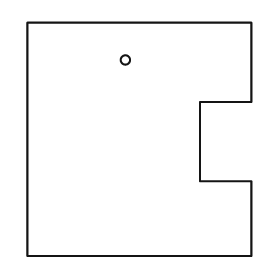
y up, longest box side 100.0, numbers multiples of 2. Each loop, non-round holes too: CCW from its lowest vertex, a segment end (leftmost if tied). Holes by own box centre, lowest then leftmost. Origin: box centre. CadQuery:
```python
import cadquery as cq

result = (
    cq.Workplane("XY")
    .moveTo(-48.0, -50.0)
    .lineTo(48.0, -50.0)
    .lineTo(48.0, -18.0)
    .lineTo(26.0, -18.0)
    .lineTo(26.0, 16.0)
    .lineTo(48.0, 16.0)
    .lineTo(48.0, 50.0)
    .lineTo(-48.0, 50.0)
    .close()
    .moveTo(-6.0, 34.0)
    .circle(2.0)
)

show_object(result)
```